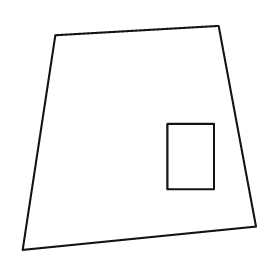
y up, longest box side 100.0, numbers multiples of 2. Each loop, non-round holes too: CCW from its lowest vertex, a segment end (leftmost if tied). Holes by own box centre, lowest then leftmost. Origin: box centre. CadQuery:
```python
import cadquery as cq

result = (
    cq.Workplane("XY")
    .moveTo(-50.0, -48.0)
    .lineTo(50.0, -38.0)
    .lineTo(34.0, 48.0)
    .lineTo(-36.0, 44.0)
    .close()
    .moveTo(12.0, -22.0)
    .lineTo(32.0, -22.0)
    .lineTo(32.0, 6.0)
    .lineTo(12.0, 6.0)
    .close()
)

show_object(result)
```